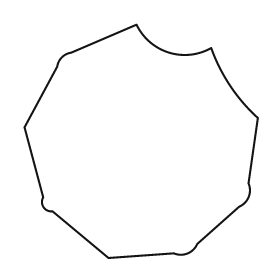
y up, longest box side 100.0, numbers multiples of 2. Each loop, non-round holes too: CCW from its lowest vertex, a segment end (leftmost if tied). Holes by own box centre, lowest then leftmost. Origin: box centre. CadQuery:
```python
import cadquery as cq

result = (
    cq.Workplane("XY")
    .moveTo(-14.0, -50.0)
    .lineTo(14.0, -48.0)
    .threePointArc((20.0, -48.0), (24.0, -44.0))
    .lineTo(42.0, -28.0)
    .threePointArc((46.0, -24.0), (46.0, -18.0))
    .lineTo(50.0, 10.0)
    .threePointArc((38.0, 24.0), (30.0, 40.0))
    .threePointArc((12.0, 38.0), (-2.0, 50.0))
    .lineTo(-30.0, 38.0)
    .threePointArc((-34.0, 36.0), (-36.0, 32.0))
    .lineTo(-50.0, 6.0)
    .lineTo(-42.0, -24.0)
    .threePointArc((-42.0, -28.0), (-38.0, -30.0))
    .close()
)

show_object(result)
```